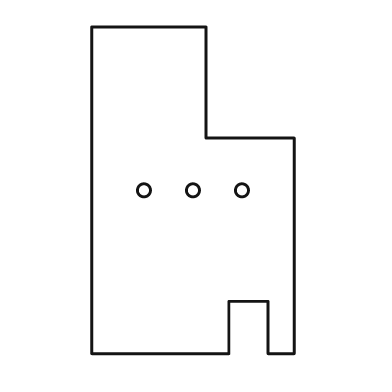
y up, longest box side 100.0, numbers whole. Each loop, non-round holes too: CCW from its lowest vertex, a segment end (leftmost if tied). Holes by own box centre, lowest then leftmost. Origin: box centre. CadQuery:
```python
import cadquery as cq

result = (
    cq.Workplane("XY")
    .moveTo(-31.0, -50.0)
    .lineTo(11.0, -50.0)
    .lineTo(11.0, -34.0)
    .lineTo(23.0, -34.0)
    .lineTo(23.0, -50.0)
    .lineTo(31.0, -50.0)
    .lineTo(31.0, 16.0)
    .lineTo(4.0, 16.0)
    .lineTo(4.0, 50.0)
    .lineTo(-31.0, 50.0)
    .close()
    .moveTo(-15.0, 0.0)
    .circle(2.0)
    .moveTo(0.0, 0.0)
    .circle(2.0)
    .moveTo(15.0, 0.0)
    .circle(2.0)
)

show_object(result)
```